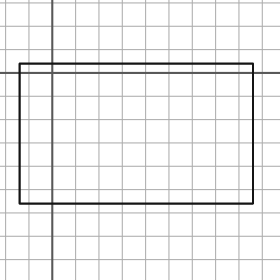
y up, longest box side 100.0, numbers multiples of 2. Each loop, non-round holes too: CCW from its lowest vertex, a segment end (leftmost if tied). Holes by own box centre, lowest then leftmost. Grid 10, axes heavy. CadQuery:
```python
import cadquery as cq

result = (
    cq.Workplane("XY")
    .moveTo(-14.0, -56.0)
    .lineTo(86.0, -56.0)
    .lineTo(86.0, 4.0)
    .lineTo(-14.0, 4.0)
    .close()
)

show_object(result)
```